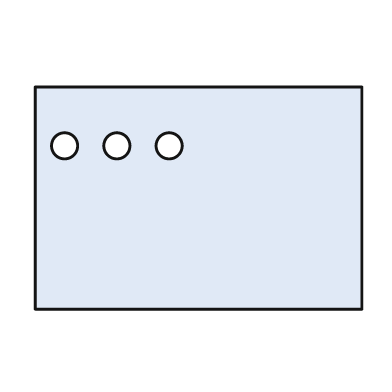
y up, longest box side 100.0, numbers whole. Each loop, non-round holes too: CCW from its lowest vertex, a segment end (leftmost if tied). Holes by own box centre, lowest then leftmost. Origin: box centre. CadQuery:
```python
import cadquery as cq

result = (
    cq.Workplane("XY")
    .moveTo(-50.0, -34.0)
    .lineTo(50.0, -34.0)
    .lineTo(50.0, 34.0)
    .lineTo(-50.0, 34.0)
    .close()
    .moveTo(-41.0, 16.0)
    .circle(4.0)
    .moveTo(-25.0, 16.0)
    .circle(4.0)
    .moveTo(-9.0, 16.0)
    .circle(4.0)
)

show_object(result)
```